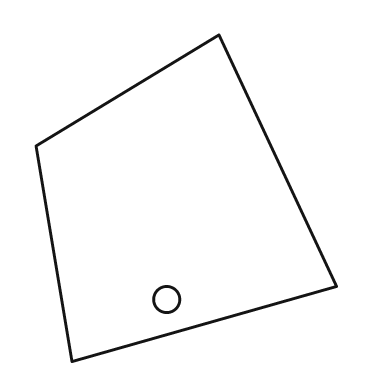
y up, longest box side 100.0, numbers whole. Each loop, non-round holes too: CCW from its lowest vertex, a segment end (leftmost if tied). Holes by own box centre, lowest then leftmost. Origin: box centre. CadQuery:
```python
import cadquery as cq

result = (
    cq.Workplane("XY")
    .moveTo(-35.0, -50.0)
    .lineTo(46.0, -27.0)
    .lineTo(10.0, 50.0)
    .lineTo(-46.0, 16.0)
    .close()
    .moveTo(-6.0, -31.0)
    .circle(4.0)
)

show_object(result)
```